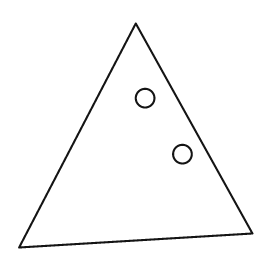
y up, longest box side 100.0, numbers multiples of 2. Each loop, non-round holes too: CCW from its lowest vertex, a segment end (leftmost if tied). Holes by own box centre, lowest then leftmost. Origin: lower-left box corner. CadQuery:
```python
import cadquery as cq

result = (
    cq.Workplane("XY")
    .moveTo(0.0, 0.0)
    .lineTo(100.0, 6.0)
    .lineTo(50.0, 96.0)
    .close()
    .moveTo(70.0, 40.0)
    .circle(4.0)
    .moveTo(54.0, 64.0)
    .circle(4.0)
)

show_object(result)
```